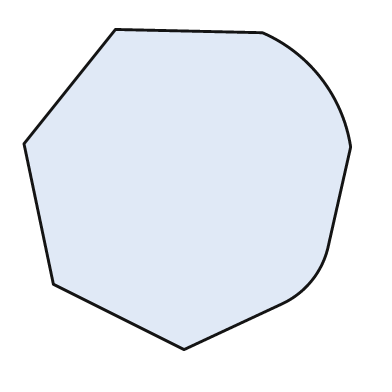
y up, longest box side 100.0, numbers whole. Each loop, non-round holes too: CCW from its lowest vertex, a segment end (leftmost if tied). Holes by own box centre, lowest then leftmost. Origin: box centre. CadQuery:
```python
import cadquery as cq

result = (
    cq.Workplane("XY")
    .moveTo(-1.0, -49.0)
    .lineTo(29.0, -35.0)
    .threePointArc((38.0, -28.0), (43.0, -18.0))
    .lineTo(50.0, 13.0)
    .threePointArc((41.0, 34.0), (23.0, 48.0))
    .lineTo(-22.0, 49.0)
    .lineTo(-50.0, 14.0)
    .lineTo(-41.0, -29.0)
    .close()
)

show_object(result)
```